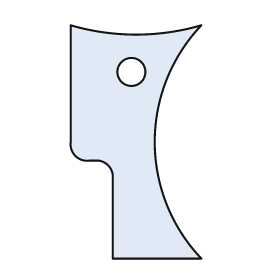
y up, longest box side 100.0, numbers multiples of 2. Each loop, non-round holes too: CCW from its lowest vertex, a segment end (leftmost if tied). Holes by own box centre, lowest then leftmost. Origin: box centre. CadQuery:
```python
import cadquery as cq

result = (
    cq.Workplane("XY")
    .moveTo(-10.0, -50.0)
    .lineTo(28.0, -50.0)
    .threePointArc((8.0, 0.0), (28.0, 50.0))
    .threePointArc((0.0, 46.0), (-28.0, 50.0))
    .lineTo(-28.0, 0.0)
    .threePointArc((-26.0, -6.0), (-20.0, -8.0))
    .lineTo(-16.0, -8.0)
    .threePointArc((-12.0, -10.0), (-10.0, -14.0))
    .close()
    .moveTo(-2.0, 30.0)
    .circle(6.0)
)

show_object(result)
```